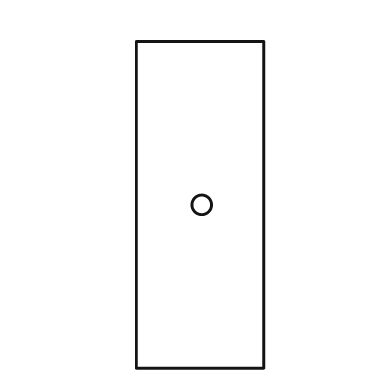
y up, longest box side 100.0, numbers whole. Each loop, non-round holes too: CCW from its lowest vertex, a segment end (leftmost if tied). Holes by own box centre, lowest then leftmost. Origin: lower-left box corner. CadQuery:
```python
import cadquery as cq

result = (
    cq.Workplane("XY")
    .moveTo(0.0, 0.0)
    .lineTo(39.0, 0.0)
    .lineTo(39.0, 100.0)
    .lineTo(0.0, 100.0)
    .close()
    .moveTo(20.0, 50.0)
    .circle(3.0)
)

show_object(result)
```